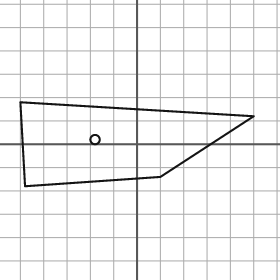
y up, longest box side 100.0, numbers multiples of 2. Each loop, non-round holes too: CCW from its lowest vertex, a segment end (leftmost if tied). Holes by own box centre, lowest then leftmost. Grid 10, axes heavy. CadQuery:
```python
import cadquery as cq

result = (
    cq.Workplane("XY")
    .moveTo(-48.0, -18.0)
    .lineTo(10.0, -14.0)
    .lineTo(50.0, 12.0)
    .lineTo(-50.0, 18.0)
    .close()
    .moveTo(-18.0, 2.0)
    .circle(2.0)
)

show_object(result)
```